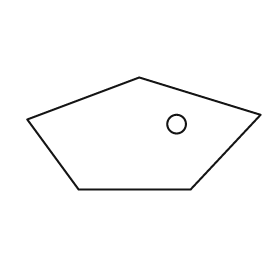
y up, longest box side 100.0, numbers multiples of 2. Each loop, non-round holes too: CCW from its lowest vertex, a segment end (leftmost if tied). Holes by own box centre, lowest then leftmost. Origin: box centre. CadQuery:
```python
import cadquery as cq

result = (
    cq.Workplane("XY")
    .moveTo(-28.0, -24.0)
    .lineTo(20.0, -24.0)
    .lineTo(50.0, 8.0)
    .lineTo(-2.0, 24.0)
    .lineTo(-50.0, 6.0)
    .close()
    .moveTo(14.0, 4.0)
    .circle(4.0)
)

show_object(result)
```